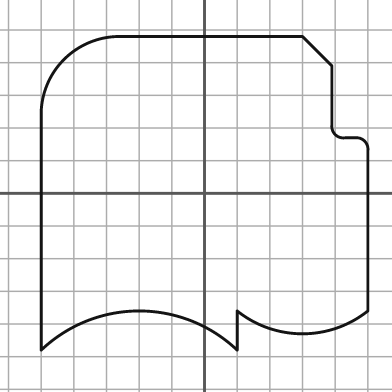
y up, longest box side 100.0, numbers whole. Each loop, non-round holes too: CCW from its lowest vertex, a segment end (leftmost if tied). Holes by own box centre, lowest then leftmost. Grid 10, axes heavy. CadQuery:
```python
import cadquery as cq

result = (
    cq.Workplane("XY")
    .moveTo(-50.0, -48.0)
    .threePointArc((-20.0, -36.0), (10.0, -48.0))
    .lineTo(10.0, -36.0)
    .threePointArc((30.0, -43.0), (50.0, -36.0))
    .lineTo(50.0, 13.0)
    .threePointArc((49.0, 16.0), (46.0, 17.0))
    .lineTo(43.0, 17.0)
    .threePointArc((40.0, 18.0), (39.0, 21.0))
    .lineTo(39.0, 39.0)
    .lineTo(30.0, 48.0)
    .lineTo(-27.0, 48.0)
    .threePointArc((-43.0, 41.0), (-50.0, 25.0))
    .close()
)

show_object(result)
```